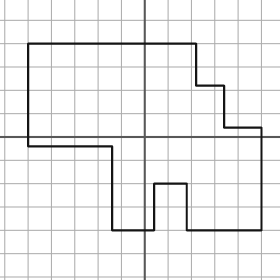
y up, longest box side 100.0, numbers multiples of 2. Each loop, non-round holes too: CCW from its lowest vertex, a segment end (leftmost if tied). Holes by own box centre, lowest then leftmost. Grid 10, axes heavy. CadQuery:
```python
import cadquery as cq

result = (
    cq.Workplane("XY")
    .moveTo(-14.0, -40.0)
    .lineTo(4.0, -40.0)
    .lineTo(4.0, -20.0)
    .lineTo(18.0, -20.0)
    .lineTo(18.0, -40.0)
    .lineTo(50.0, -40.0)
    .lineTo(50.0, 4.0)
    .lineTo(34.0, 4.0)
    .lineTo(34.0, 22.0)
    .lineTo(22.0, 22.0)
    .lineTo(22.0, 40.0)
    .lineTo(-50.0, 40.0)
    .lineTo(-50.0, -4.0)
    .lineTo(-14.0, -4.0)
    .close()
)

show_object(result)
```